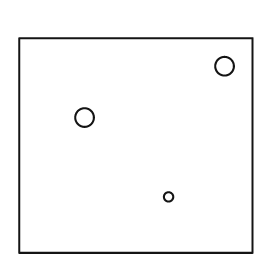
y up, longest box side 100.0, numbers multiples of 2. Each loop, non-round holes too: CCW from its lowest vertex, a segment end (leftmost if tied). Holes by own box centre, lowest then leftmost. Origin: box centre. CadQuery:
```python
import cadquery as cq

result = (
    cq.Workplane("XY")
    .moveTo(-50.0, -46.0)
    .lineTo(50.0, -46.0)
    .lineTo(50.0, 46.0)
    .lineTo(-50.0, 46.0)
    .close()
    .moveTo(14.0, -22.0)
    .circle(2.0)
    .moveTo(-22.0, 12.0)
    .circle(4.0)
    .moveTo(38.0, 34.0)
    .circle(4.0)
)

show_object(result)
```